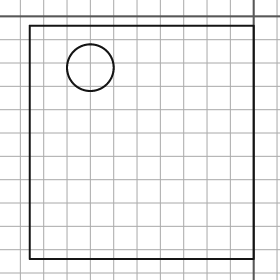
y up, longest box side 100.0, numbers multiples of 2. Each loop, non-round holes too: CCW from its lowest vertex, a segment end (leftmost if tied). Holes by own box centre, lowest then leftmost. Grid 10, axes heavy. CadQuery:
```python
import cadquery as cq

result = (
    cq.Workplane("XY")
    .moveTo(-96.0, -104.0)
    .lineTo(0.0, -104.0)
    .lineTo(0.0, -4.0)
    .lineTo(-96.0, -4.0)
    .close()
    .moveTo(-70.0, -22.0)
    .circle(10.0)
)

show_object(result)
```